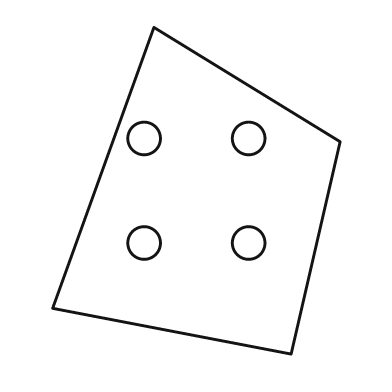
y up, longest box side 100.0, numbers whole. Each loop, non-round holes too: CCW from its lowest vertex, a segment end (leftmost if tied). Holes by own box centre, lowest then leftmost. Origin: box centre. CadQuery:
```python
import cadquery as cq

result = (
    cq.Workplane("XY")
    .moveTo(29.0, -50.0)
    .lineTo(44.0, 15.0)
    .lineTo(-13.0, 50.0)
    .lineTo(-44.0, -36.0)
    .close()
    .moveTo(-16.0, -16.0)
    .circle(5.0)
    .moveTo(16.0, -16.0)
    .circle(5.0)
    .moveTo(-16.0, 16.0)
    .circle(5.0)
    .moveTo(16.0, 16.0)
    .circle(5.0)
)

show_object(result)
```